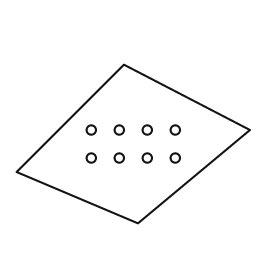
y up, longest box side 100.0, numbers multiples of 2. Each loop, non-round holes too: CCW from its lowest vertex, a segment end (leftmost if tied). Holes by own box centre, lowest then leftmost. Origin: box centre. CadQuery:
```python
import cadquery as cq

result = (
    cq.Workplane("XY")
    .moveTo(2.0, -34.0)
    .lineTo(50.0, 6.0)
    .lineTo(-4.0, 34.0)
    .lineTo(-50.0, -12.0)
    .close()
    .moveTo(-18.0, -6.0)
    .circle(2.0)
    .moveTo(-6.0, -6.0)
    .circle(2.0)
    .moveTo(6.0, -6.0)
    .circle(2.0)
    .moveTo(18.0, -6.0)
    .circle(2.0)
    .moveTo(-18.0, 6.0)
    .circle(2.0)
    .moveTo(-6.0, 6.0)
    .circle(2.0)
    .moveTo(6.0, 6.0)
    .circle(2.0)
    .moveTo(18.0, 6.0)
    .circle(2.0)
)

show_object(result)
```